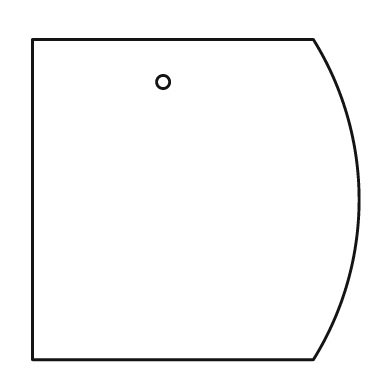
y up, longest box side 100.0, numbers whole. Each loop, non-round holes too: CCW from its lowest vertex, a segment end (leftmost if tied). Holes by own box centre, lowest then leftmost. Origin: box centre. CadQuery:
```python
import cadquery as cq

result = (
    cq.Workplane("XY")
    .moveTo(-50.0, -49.0)
    .lineTo(36.0, -49.0)
    .threePointArc((50.0, 0.0), (36.0, 49.0))
    .lineTo(-50.0, 49.0)
    .close()
    .moveTo(-10.0, 36.0)
    .circle(2.0)
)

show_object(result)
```